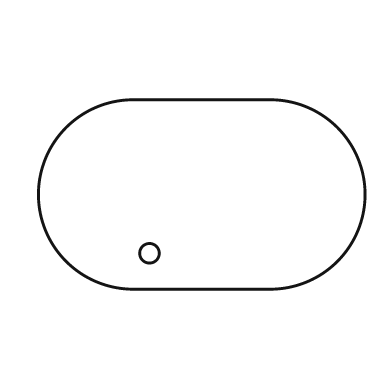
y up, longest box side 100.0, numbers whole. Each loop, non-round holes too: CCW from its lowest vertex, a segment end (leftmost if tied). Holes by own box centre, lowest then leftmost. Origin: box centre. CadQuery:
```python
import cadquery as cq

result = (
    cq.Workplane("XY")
    .moveTo(-21.0, -29.0)
    .lineTo(21.0, -29.0)
    .threePointArc((50.0, 0.0), (21.0, 29.0))
    .lineTo(-21.0, 29.0)
    .threePointArc((-50.0, 0.0), (-21.0, -29.0))
    .close()
    .moveTo(-16.0, -18.0)
    .circle(3.0)
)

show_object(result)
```